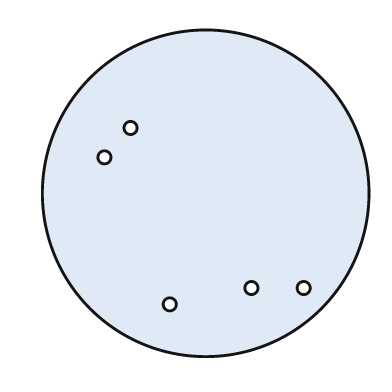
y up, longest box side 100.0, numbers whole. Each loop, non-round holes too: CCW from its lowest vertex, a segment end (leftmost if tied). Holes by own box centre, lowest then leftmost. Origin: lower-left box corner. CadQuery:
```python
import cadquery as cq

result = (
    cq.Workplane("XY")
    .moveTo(50.0, 50.0)
    .circle(50.0)
    .moveTo(39.0, 16.0)
    .circle(2.0)
    .moveTo(64.0, 21.0)
    .circle(2.0)
    .moveTo(80.0, 21.0)
    .circle(2.0)
    .moveTo(19.0, 61.0)
    .circle(2.0)
    .moveTo(27.0, 70.0)
    .circle(2.0)
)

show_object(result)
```